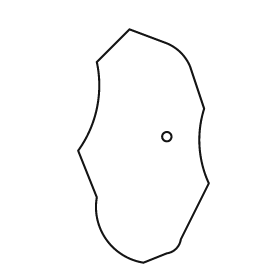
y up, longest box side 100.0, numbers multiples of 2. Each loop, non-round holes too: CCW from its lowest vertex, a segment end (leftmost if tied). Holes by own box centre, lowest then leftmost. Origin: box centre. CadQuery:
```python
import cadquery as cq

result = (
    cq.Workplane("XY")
    .moveTo(0.0, -50.0)
    .lineTo(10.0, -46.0)
    .threePointArc((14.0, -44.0), (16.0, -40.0))
    .lineTo(28.0, -16.0)
    .threePointArc((24.0, 0.0), (26.0, 16.0))
    .lineTo(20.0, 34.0)
    .threePointArc((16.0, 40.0), (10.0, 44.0))
    .lineTo(-6.0, 50.0)
    .lineTo(-20.0, 36.0)
    .threePointArc((-20.0, 16.0), (-28.0, -2.0))
    .lineTo(-20.0, -22.0)
    .threePointArc((-16.0, -40.0), (0.0, -50.0))
    .close()
    .moveTo(10.0, 4.0)
    .circle(2.0)
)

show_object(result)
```